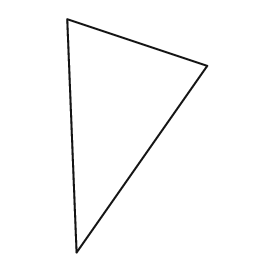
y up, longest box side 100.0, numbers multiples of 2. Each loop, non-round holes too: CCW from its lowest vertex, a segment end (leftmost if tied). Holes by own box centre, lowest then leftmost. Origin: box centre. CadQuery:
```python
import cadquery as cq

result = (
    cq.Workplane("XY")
    .moveTo(-26.0, -50.0)
    .lineTo(30.0, 30.0)
    .lineTo(-30.0, 50.0)
    .close()
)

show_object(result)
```